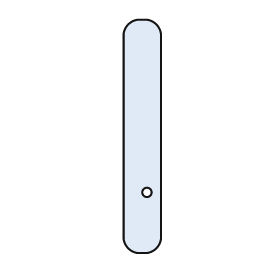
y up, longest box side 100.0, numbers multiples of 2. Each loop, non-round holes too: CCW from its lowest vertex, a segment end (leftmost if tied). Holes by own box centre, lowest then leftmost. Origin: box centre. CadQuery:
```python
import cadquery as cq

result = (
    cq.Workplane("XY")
    .moveTo(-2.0, -50.0)
    .lineTo(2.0, -50.0)
    .threePointArc((6.0, -48.0), (8.0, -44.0))
    .lineTo(8.0, 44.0)
    .threePointArc((6.0, 48.0), (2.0, 50.0))
    .lineTo(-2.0, 50.0)
    .threePointArc((-6.0, 48.0), (-8.0, 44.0))
    .lineTo(-8.0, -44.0)
    .threePointArc((-6.0, -48.0), (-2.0, -50.0))
    .close()
    .moveTo(2.0, -24.0)
    .circle(2.0)
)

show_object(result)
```